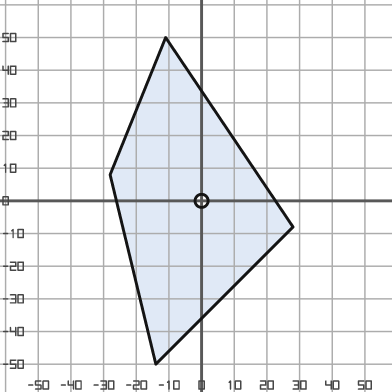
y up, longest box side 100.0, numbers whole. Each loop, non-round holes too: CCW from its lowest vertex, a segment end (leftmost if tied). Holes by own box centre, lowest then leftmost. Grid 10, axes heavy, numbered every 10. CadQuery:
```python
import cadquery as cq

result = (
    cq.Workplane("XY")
    .moveTo(-14.0, -50.0)
    .lineTo(28.0, -8.0)
    .lineTo(-11.0, 50.0)
    .lineTo(-28.0, 8.0)
    .close()
    .moveTo(0.0, 0.0)
    .circle(2.0)
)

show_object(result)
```